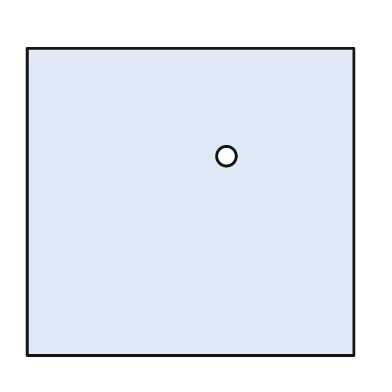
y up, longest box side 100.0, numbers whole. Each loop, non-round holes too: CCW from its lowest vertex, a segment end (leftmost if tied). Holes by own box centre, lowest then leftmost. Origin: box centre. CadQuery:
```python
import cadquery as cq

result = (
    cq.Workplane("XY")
    .moveTo(-50.0, -47.0)
    .lineTo(50.0, -47.0)
    .lineTo(50.0, 47.0)
    .lineTo(-50.0, 47.0)
    .close()
    .moveTo(11.0, 14.0)
    .circle(3.0)
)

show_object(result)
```